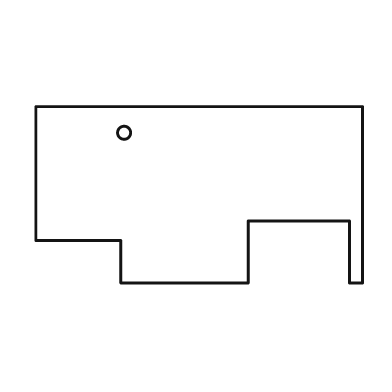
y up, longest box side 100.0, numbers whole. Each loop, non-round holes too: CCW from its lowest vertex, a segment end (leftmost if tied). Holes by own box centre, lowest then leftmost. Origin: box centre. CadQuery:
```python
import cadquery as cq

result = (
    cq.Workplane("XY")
    .moveTo(-24.0, -27.0)
    .lineTo(15.0, -27.0)
    .lineTo(15.0, -8.0)
    .lineTo(46.0, -8.0)
    .lineTo(46.0, -27.0)
    .lineTo(50.0, -27.0)
    .lineTo(50.0, 27.0)
    .lineTo(-50.0, 27.0)
    .lineTo(-50.0, -14.0)
    .lineTo(-24.0, -14.0)
    .close()
    .moveTo(-23.0, 19.0)
    .circle(2.0)
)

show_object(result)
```